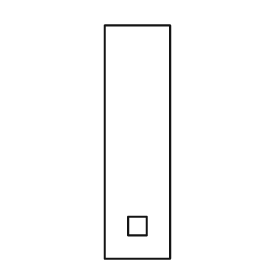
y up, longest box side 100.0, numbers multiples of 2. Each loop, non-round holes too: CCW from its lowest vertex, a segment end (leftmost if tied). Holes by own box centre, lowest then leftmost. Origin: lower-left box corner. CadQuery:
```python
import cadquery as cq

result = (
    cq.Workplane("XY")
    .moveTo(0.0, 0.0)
    .lineTo(28.0, 0.0)
    .lineTo(28.0, 100.0)
    .lineTo(0.0, 100.0)
    .close()
    .moveTo(10.0, 10.0)
    .lineTo(18.0, 10.0)
    .lineTo(18.0, 18.0)
    .lineTo(10.0, 18.0)
    .close()
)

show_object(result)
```